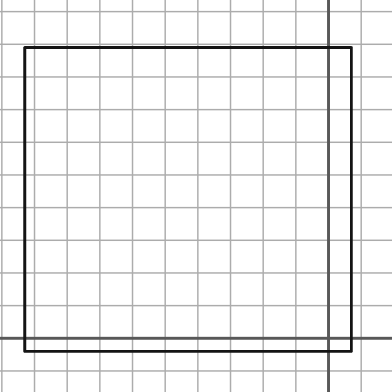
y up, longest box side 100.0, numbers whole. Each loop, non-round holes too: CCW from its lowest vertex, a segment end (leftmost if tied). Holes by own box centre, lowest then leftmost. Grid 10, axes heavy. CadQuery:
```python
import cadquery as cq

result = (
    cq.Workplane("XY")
    .moveTo(-93.0, -4.0)
    .lineTo(7.0, -4.0)
    .lineTo(7.0, 89.0)
    .lineTo(-93.0, 89.0)
    .close()
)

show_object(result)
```